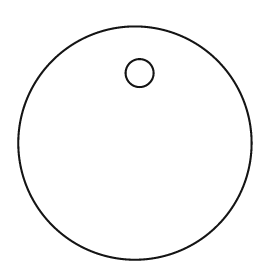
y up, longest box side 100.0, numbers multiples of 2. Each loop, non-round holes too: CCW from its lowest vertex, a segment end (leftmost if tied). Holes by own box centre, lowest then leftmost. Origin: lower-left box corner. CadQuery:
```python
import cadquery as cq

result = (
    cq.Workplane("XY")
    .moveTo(50.0, 50.0)
    .circle(50.0)
    .moveTo(52.0, 80.0)
    .circle(6.0)
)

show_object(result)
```